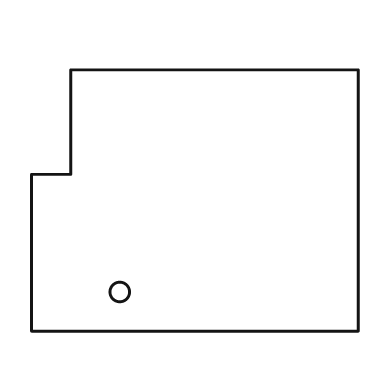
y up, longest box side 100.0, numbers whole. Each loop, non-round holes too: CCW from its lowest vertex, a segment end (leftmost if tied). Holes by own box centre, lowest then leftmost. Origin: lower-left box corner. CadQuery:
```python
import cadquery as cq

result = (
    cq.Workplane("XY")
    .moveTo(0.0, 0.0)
    .lineTo(100.0, 0.0)
    .lineTo(100.0, 80.0)
    .lineTo(12.0, 80.0)
    .lineTo(12.0, 48.0)
    .lineTo(0.0, 48.0)
    .close()
    .moveTo(27.0, 12.0)
    .circle(3.0)
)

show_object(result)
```